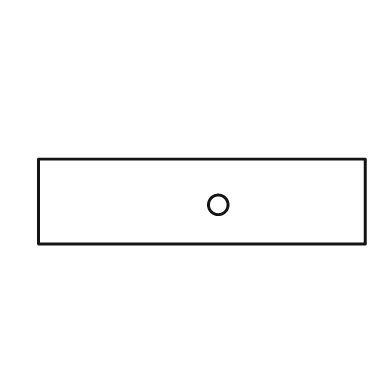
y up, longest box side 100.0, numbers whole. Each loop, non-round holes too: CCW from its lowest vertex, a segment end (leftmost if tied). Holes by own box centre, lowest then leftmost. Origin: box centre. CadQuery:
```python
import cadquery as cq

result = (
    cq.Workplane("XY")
    .moveTo(-50.0, -13.0)
    .lineTo(50.0, -13.0)
    .lineTo(50.0, 13.0)
    .lineTo(-50.0, 13.0)
    .close()
    .moveTo(5.0, -1.0)
    .circle(3.0)
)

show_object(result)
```